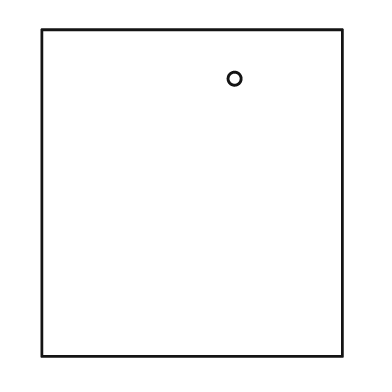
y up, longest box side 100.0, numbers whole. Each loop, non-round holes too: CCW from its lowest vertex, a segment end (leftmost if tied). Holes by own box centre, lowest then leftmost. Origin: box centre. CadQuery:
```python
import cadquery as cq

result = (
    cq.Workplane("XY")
    .moveTo(-46.0, -50.0)
    .lineTo(46.0, -50.0)
    .lineTo(46.0, 50.0)
    .lineTo(-46.0, 50.0)
    .close()
    .moveTo(13.0, 35.0)
    .circle(2.0)
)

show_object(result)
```